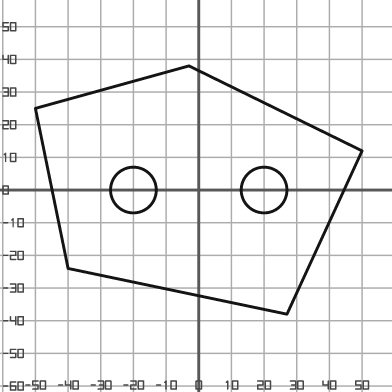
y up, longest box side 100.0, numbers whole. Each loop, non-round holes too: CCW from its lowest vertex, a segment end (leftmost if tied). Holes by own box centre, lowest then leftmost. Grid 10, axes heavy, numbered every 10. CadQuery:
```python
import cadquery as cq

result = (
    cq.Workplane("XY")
    .moveTo(27.0, -38.0)
    .lineTo(50.0, 12.0)
    .lineTo(-3.0, 38.0)
    .lineTo(-50.0, 25.0)
    .lineTo(-40.0, -24.0)
    .close()
    .moveTo(-20.0, 0.0)
    .circle(7.0)
    .moveTo(20.0, 0.0)
    .circle(7.0)
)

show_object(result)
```